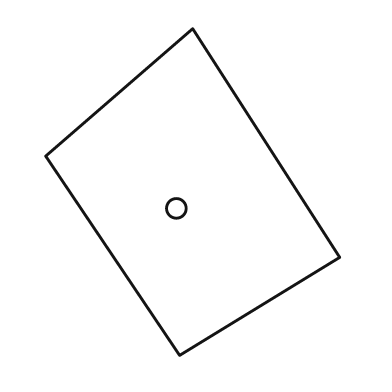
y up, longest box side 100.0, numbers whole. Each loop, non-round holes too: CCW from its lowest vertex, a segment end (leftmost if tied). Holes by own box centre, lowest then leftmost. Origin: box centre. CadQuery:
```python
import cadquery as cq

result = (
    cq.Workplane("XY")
    .moveTo(-4.0, -50.0)
    .lineTo(45.0, -20.0)
    .lineTo(0.0, 50.0)
    .lineTo(-45.0, 11.0)
    .close()
    .moveTo(-5.0, -5.0)
    .circle(3.0)
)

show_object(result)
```